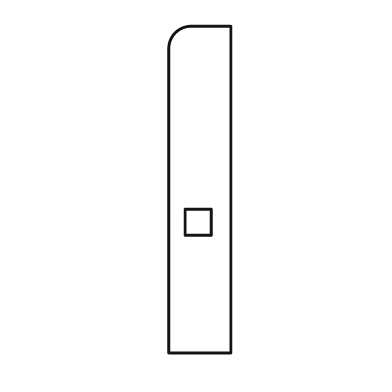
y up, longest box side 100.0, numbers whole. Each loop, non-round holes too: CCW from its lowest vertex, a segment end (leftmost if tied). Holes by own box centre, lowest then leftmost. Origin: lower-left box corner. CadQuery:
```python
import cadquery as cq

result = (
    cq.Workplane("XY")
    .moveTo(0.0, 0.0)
    .lineTo(19.0, 0.0)
    .lineTo(19.0, 100.0)
    .lineTo(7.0, 100.0)
    .threePointArc((2.0, 98.0), (0.0, 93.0))
    .close()
    .moveTo(5.0, 36.0)
    .lineTo(13.0, 36.0)
    .lineTo(13.0, 44.0)
    .lineTo(5.0, 44.0)
    .close()
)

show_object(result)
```